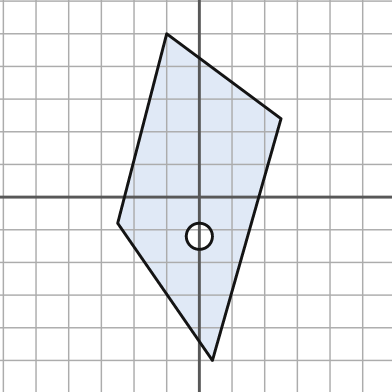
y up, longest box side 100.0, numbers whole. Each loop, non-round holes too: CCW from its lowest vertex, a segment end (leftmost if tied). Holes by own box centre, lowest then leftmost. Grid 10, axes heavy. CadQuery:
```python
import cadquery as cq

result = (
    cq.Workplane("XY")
    .moveTo(4.0, -50.0)
    .lineTo(25.0, 24.0)
    .lineTo(-10.0, 50.0)
    .lineTo(-25.0, -8.0)
    .close()
    .moveTo(0.0, -12.0)
    .circle(4.0)
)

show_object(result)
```